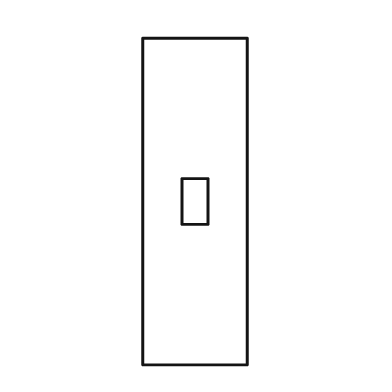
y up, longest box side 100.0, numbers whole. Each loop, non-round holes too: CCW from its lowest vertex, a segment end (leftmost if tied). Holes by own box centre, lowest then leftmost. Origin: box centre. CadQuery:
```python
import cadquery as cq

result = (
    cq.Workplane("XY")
    .moveTo(-16.0, -50.0)
    .lineTo(16.0, -50.0)
    .lineTo(16.0, 50.0)
    .lineTo(-16.0, 50.0)
    .close()
    .moveTo(-4.0, -7.0)
    .lineTo(4.0, -7.0)
    .lineTo(4.0, 7.0)
    .lineTo(-4.0, 7.0)
    .close()
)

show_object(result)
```